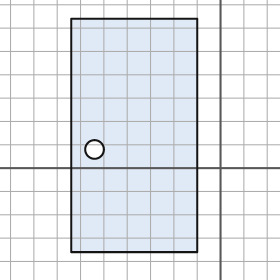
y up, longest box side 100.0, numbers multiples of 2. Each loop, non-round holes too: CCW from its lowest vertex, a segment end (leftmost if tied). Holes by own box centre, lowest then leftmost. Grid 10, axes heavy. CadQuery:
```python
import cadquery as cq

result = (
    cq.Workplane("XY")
    .moveTo(-64.0, -36.0)
    .lineTo(-10.0, -36.0)
    .lineTo(-10.0, 64.0)
    .lineTo(-64.0, 64.0)
    .close()
    .moveTo(-54.0, 8.0)
    .circle(4.0)
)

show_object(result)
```